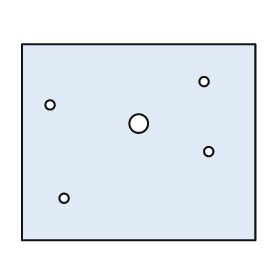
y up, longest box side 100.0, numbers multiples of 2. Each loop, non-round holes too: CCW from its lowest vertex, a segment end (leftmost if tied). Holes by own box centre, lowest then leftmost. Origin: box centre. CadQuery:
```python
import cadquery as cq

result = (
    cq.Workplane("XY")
    .moveTo(-50.0, -42.0)
    .lineTo(50.0, -42.0)
    .lineTo(50.0, 42.0)
    .lineTo(-50.0, 42.0)
    .close()
    .moveTo(-32.0, -24.0)
    .circle(2.0)
    .moveTo(30.0, -4.0)
    .circle(2.0)
    .moveTo(0.0, 8.0)
    .circle(4.0)
    .moveTo(-38.0, 16.0)
    .circle(2.0)
    .moveTo(28.0, 26.0)
    .circle(2.0)
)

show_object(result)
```